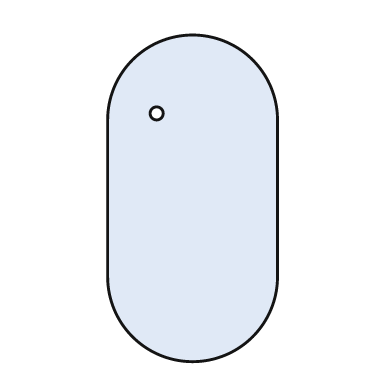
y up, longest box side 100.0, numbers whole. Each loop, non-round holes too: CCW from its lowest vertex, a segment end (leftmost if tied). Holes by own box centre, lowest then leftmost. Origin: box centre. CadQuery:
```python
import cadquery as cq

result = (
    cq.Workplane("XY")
    .moveTo(-26.0, -24.0)
    .threePointArc((0.0, -50.0), (26.0, -24.0))
    .lineTo(26.0, 24.0)
    .threePointArc((0.0, 50.0), (-26.0, 24.0))
    .close()
    .moveTo(-11.0, 26.0)
    .circle(2.0)
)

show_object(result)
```